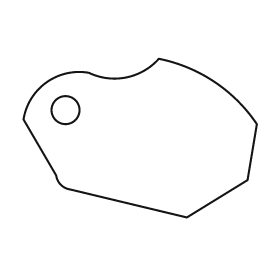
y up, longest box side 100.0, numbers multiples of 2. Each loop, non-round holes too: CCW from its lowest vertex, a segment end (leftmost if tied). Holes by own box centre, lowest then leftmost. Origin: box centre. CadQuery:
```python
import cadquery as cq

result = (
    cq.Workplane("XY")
    .moveTo(20.0, -34.0)
    .lineTo(46.0, -18.0)
    .lineTo(50.0, 6.0)
    .threePointArc((32.0, 24.0), (8.0, 34.0))
    .threePointArc((-6.0, 26.0), (-22.0, 28.0))
    .threePointArc((-40.0, 24.0), (-50.0, 8.0))
    .lineTo(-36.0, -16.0)
    .threePointArc((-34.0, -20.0), (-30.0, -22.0))
    .close()
    .moveTo(-32.0, 12.0)
    .circle(6.0)
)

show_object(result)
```